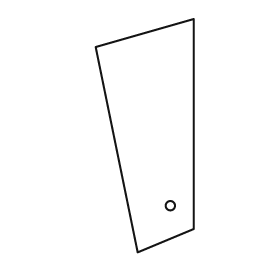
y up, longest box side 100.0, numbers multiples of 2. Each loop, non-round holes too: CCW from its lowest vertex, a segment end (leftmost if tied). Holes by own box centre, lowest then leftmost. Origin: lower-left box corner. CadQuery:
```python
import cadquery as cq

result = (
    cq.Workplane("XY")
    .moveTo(18.0, 0.0)
    .lineTo(42.0, 10.0)
    .lineTo(42.0, 100.0)
    .lineTo(0.0, 88.0)
    .close()
    .moveTo(32.0, 20.0)
    .circle(2.0)
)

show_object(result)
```